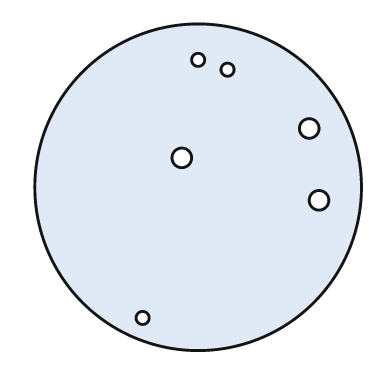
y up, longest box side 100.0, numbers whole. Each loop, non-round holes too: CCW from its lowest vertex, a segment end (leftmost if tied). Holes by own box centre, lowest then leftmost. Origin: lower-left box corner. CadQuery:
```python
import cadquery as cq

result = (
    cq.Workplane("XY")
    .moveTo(50.0, 50.0)
    .circle(50.0)
    .moveTo(33.0, 10.0)
    .circle(2.0)
    .moveTo(87.0, 46.0)
    .circle(3.0)
    .moveTo(45.0, 59.0)
    .circle(3.0)
    .moveTo(84.0, 68.0)
    .circle(3.0)
    .moveTo(59.0, 86.0)
    .circle(2.0)
    .moveTo(50.0, 89.0)
    .circle(2.0)
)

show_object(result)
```